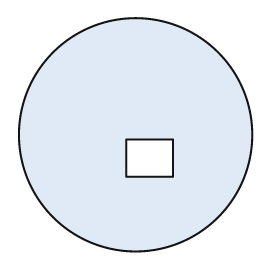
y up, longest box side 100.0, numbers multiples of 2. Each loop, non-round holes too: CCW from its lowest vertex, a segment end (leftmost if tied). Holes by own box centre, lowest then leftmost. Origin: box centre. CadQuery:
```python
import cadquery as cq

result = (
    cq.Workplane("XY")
    .moveTo(0.0, 0.0)
    .circle(50.0)
    .moveTo(-4.0, -18.0)
    .lineTo(16.0, -18.0)
    .lineTo(16.0, -2.0)
    .lineTo(-4.0, -2.0)
    .close()
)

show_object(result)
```